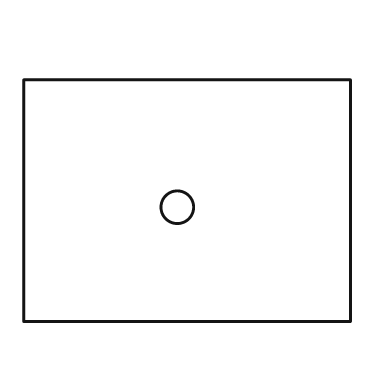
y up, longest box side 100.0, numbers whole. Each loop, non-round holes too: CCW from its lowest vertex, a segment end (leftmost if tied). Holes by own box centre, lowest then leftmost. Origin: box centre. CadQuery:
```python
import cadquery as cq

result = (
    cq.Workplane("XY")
    .moveTo(-50.0, -37.0)
    .lineTo(50.0, -37.0)
    .lineTo(50.0, 37.0)
    .lineTo(-50.0, 37.0)
    .close()
    .moveTo(-3.0, -2.0)
    .circle(5.0)
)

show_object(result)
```